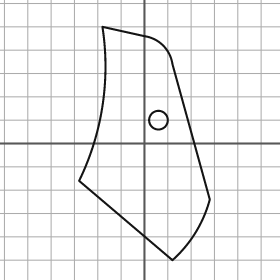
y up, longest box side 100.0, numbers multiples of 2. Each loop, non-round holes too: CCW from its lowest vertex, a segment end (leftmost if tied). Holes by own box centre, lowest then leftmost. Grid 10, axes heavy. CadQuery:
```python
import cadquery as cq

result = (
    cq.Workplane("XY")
    .moveTo(12.0, -50.0)
    .threePointArc((22.0, -38.0), (28.0, -24.0))
    .lineTo(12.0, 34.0)
    .threePointArc((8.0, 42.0), (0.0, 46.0))
    .lineTo(-18.0, 50.0)
    .threePointArc((-18.0, 16.0), (-28.0, -16.0))
    .close()
    .moveTo(6.0, 10.0)
    .circle(4.0)
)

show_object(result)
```